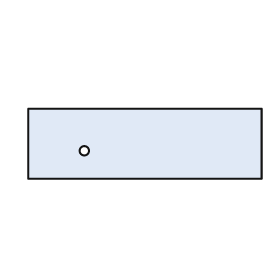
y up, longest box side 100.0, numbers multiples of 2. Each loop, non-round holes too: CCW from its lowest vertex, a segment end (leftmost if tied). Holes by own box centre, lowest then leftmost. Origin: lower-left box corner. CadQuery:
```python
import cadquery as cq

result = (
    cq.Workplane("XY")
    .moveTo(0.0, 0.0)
    .lineTo(100.0, 0.0)
    .lineTo(100.0, 30.0)
    .lineTo(0.0, 30.0)
    .close()
    .moveTo(24.0, 12.0)
    .circle(2.0)
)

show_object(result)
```